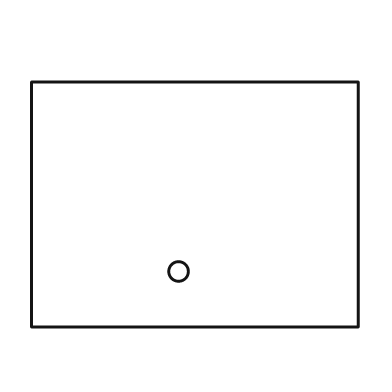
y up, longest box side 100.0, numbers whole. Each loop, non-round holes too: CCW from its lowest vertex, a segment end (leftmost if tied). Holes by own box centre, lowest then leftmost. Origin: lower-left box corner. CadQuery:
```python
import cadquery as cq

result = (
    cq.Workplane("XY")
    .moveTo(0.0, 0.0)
    .lineTo(100.0, 0.0)
    .lineTo(100.0, 75.0)
    .lineTo(0.0, 75.0)
    .close()
    .moveTo(45.0, 17.0)
    .circle(3.0)
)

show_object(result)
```